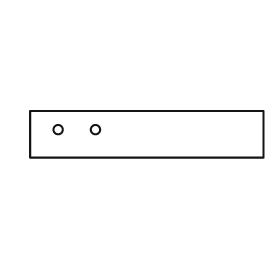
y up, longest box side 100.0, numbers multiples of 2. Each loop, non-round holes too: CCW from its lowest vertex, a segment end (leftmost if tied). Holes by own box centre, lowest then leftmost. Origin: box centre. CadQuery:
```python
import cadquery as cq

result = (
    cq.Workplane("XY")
    .moveTo(-50.0, -10.0)
    .lineTo(50.0, -10.0)
    .lineTo(50.0, 10.0)
    .lineTo(-50.0, 10.0)
    .close()
    .moveTo(-38.0, 2.0)
    .circle(2.0)
    .moveTo(-22.0, 2.0)
    .circle(2.0)
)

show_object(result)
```